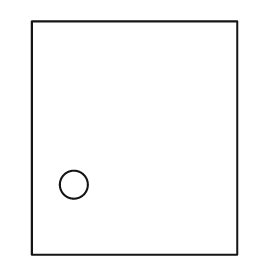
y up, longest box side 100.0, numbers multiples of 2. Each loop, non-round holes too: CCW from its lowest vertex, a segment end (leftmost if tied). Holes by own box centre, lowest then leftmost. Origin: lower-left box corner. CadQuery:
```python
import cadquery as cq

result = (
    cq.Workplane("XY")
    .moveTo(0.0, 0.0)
    .lineTo(88.0, 0.0)
    .lineTo(88.0, 100.0)
    .lineTo(0.0, 100.0)
    .close()
    .moveTo(18.0, 30.0)
    .circle(6.0)
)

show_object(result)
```